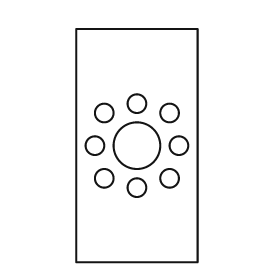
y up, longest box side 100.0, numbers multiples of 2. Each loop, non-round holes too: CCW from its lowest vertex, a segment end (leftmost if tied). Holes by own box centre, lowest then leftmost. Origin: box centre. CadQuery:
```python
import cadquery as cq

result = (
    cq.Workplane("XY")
    .moveTo(-26.0, -50.0)
    .lineTo(26.0, -50.0)
    .lineTo(26.0, 50.0)
    .lineTo(-26.0, 50.0)
    .close()
    .moveTo(0.0, -18.0)
    .circle(4.0)
    .moveTo(-14.0, -14.0)
    .circle(4.0)
    .moveTo(14.0, -14.0)
    .circle(4.0)
    .moveTo(-18.0, 0.0)
    .circle(4.0)
    .moveTo(0.0, 0.0)
    .circle(10.0)
    .moveTo(18.0, 0.0)
    .circle(4.0)
    .moveTo(-14.0, 14.0)
    .circle(4.0)
    .moveTo(14.0, 14.0)
    .circle(4.0)
    .moveTo(0.0, 18.0)
    .circle(4.0)
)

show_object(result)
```